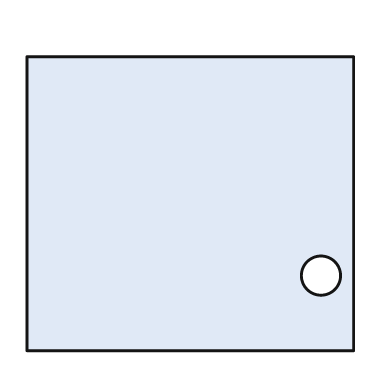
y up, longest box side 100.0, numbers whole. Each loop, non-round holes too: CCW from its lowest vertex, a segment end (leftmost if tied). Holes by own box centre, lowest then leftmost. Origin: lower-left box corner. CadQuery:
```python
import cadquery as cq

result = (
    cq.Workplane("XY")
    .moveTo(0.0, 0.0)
    .lineTo(100.0, 0.0)
    .lineTo(100.0, 90.0)
    .lineTo(0.0, 90.0)
    .close()
    .moveTo(90.0, 23.0)
    .circle(6.0)
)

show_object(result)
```